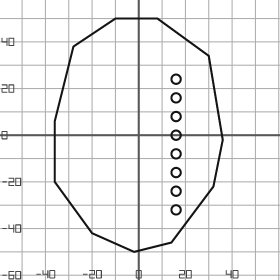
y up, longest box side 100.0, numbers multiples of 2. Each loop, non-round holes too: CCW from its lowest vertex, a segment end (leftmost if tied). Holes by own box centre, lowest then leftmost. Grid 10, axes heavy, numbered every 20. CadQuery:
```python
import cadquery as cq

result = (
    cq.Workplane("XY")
    .moveTo(-2.0, -50.0)
    .lineTo(14.0, -46.0)
    .lineTo(32.0, -22.0)
    .lineTo(36.0, -2.0)
    .lineTo(30.0, 34.0)
    .lineTo(8.0, 50.0)
    .lineTo(-10.0, 50.0)
    .lineTo(-28.0, 38.0)
    .lineTo(-36.0, 6.0)
    .lineTo(-36.0, -20.0)
    .lineTo(-20.0, -42.0)
    .close()
    .moveTo(16.0, -32.0)
    .circle(2.0)
    .moveTo(16.0, -24.0)
    .circle(2.0)
    .moveTo(16.0, -16.0)
    .circle(2.0)
    .moveTo(16.0, -8.0)
    .circle(2.0)
    .moveTo(16.0, 0.0)
    .circle(2.0)
    .moveTo(16.0, 8.0)
    .circle(2.0)
    .moveTo(16.0, 16.0)
    .circle(2.0)
    .moveTo(16.0, 24.0)
    .circle(2.0)
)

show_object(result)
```